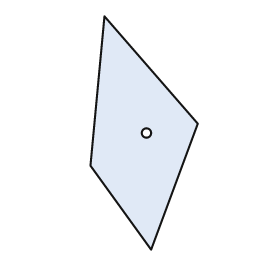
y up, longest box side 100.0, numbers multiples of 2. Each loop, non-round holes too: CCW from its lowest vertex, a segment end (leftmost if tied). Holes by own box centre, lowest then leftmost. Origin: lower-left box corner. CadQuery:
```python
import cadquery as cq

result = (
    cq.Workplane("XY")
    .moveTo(26.0, 0.0)
    .lineTo(46.0, 54.0)
    .lineTo(6.0, 100.0)
    .lineTo(0.0, 36.0)
    .close()
    .moveTo(24.0, 50.0)
    .circle(2.0)
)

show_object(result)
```